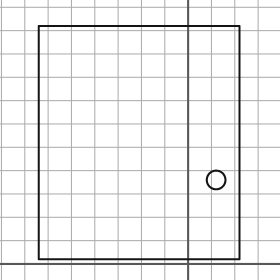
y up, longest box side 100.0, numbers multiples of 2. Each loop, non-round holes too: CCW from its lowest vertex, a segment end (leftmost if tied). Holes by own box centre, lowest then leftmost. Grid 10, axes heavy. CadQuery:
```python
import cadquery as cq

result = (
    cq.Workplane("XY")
    .moveTo(-64.0, 2.0)
    .lineTo(22.0, 2.0)
    .lineTo(22.0, 102.0)
    .lineTo(-64.0, 102.0)
    .close()
    .moveTo(12.0, 36.0)
    .circle(4.0)
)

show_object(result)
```